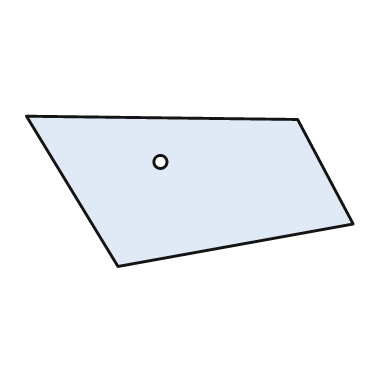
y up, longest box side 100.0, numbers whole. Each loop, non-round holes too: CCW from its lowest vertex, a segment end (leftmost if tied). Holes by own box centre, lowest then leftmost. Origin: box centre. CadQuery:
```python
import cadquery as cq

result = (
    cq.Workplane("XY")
    .moveTo(-22.0, -23.0)
    .lineTo(50.0, -10.0)
    .lineTo(33.0, 22.0)
    .lineTo(-50.0, 23.0)
    .close()
    .moveTo(-9.0, 9.0)
    .circle(2.0)
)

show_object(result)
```